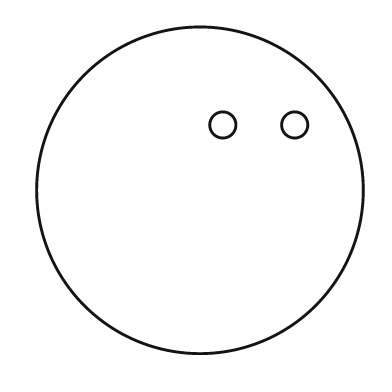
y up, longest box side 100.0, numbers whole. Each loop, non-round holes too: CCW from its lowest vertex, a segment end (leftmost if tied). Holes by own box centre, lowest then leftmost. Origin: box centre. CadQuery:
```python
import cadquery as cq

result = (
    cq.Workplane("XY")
    .moveTo(0.0, 0.0)
    .circle(50.0)
    .moveTo(7.0, 20.0)
    .circle(4.0)
    .moveTo(29.0, 20.0)
    .circle(4.0)
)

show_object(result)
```